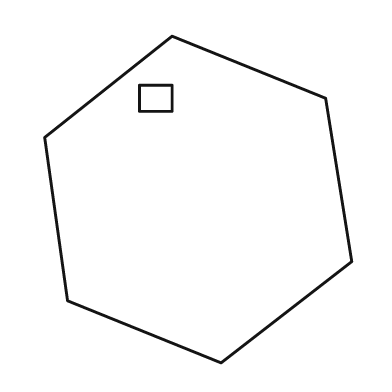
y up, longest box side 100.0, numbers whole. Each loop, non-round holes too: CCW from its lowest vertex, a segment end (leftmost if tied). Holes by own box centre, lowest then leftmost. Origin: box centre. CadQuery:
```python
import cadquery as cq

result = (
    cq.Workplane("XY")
    .moveTo(7.0, -50.0)
    .lineTo(47.0, -19.0)
    .lineTo(39.0, 31.0)
    .lineTo(-8.0, 50.0)
    .lineTo(-47.0, 19.0)
    .lineTo(-40.0, -31.0)
    .close()
    .moveTo(-18.0, 27.0)
    .lineTo(-8.0, 27.0)
    .lineTo(-8.0, 35.0)
    .lineTo(-18.0, 35.0)
    .close()
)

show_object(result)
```